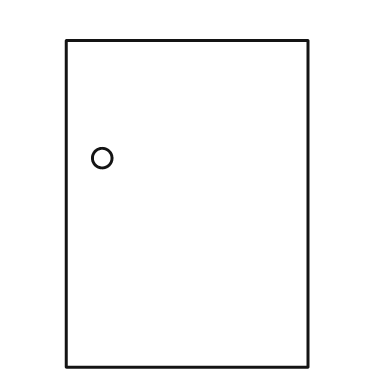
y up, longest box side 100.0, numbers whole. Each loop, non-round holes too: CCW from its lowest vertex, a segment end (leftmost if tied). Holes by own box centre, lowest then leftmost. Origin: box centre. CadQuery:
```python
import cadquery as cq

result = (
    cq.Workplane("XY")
    .moveTo(-37.0, -50.0)
    .lineTo(37.0, -50.0)
    .lineTo(37.0, 50.0)
    .lineTo(-37.0, 50.0)
    .close()
    .moveTo(-26.0, 14.0)
    .circle(3.0)
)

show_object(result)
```